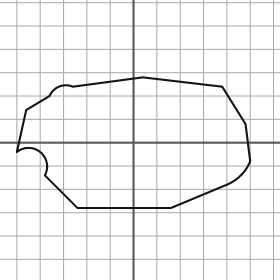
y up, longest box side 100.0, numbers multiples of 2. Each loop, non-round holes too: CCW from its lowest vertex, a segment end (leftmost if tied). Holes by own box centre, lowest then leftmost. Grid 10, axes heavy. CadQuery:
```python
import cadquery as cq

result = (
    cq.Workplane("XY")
    .moveTo(-24.0, -28.0)
    .lineTo(16.0, -28.0)
    .lineTo(40.0, -18.0)
    .threePointArc((46.0, -14.0), (50.0, -8.0))
    .lineTo(48.0, 8.0)
    .lineTo(38.0, 24.0)
    .lineTo(4.0, 28.0)
    .lineTo(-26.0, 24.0)
    .threePointArc((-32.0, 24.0), (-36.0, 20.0))
    .lineTo(-46.0, 14.0)
    .lineTo(-50.0, -4.0)
    .threePointArc((-40.0, -4.0), (-38.0, -14.0))
    .close()
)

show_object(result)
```